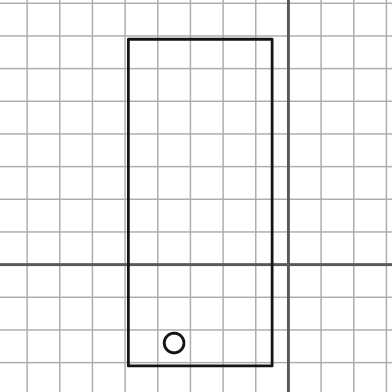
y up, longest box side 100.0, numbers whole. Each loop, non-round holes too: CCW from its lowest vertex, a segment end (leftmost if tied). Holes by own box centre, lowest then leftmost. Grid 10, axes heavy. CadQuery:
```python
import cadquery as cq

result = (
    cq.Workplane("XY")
    .moveTo(-49.0, -31.0)
    .lineTo(-5.0, -31.0)
    .lineTo(-5.0, 69.0)
    .lineTo(-49.0, 69.0)
    .close()
    .moveTo(-35.0, -24.0)
    .circle(3.0)
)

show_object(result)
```